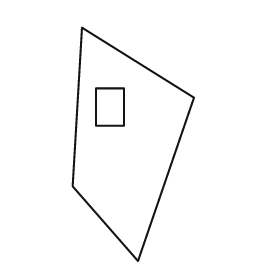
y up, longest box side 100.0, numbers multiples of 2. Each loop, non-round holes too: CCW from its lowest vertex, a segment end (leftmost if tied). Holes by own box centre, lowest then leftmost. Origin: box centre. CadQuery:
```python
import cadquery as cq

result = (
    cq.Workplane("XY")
    .moveTo(2.0, -50.0)
    .lineTo(26.0, 20.0)
    .lineTo(-22.0, 50.0)
    .lineTo(-26.0, -18.0)
    .close()
    .moveTo(-16.0, 8.0)
    .lineTo(-4.0, 8.0)
    .lineTo(-4.0, 24.0)
    .lineTo(-16.0, 24.0)
    .close()
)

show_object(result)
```